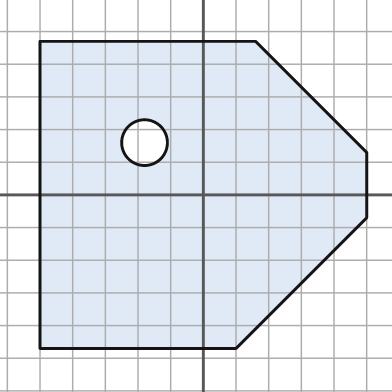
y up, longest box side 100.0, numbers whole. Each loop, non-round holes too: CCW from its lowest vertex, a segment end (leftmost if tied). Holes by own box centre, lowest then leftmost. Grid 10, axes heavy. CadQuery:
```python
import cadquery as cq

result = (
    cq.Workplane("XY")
    .moveTo(-50.0, -47.0)
    .lineTo(10.0, -47.0)
    .lineTo(50.0, -7.0)
    .lineTo(50.0, 13.0)
    .lineTo(16.0, 47.0)
    .lineTo(-50.0, 47.0)
    .close()
    .moveTo(-18.0, 16.0)
    .circle(7.0)
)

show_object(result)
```